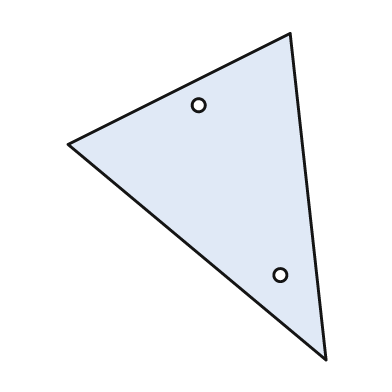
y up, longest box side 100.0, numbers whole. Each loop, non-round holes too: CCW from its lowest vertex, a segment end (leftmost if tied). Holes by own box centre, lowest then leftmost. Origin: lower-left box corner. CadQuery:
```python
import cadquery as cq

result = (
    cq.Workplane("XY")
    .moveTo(79.0, 0.0)
    .lineTo(68.0, 100.0)
    .lineTo(0.0, 66.0)
    .close()
    .moveTo(65.0, 26.0)
    .circle(2.0)
    .moveTo(40.0, 78.0)
    .circle(2.0)
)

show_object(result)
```